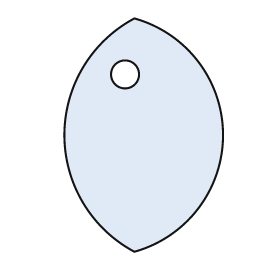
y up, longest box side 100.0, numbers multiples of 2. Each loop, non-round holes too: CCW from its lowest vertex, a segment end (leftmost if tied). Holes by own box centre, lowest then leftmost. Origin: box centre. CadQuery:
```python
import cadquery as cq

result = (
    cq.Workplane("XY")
    .moveTo(-4.0, -50.0)
    .threePointArc((34.0, 0.0), (-4.0, 50.0))
    .threePointArc((-34.0, 0.0), (-4.0, -50.0))
    .close()
    .moveTo(-8.0, 26.0)
    .circle(6.0)
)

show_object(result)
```